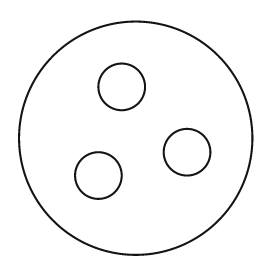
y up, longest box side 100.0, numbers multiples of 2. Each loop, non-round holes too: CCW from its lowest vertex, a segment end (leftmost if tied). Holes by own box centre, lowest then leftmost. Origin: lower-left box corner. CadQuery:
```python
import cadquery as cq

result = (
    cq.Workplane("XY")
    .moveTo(50.0, 50.0)
    .circle(50.0)
    .moveTo(34.0, 34.0)
    .circle(10.0)
    .moveTo(72.0, 44.0)
    .circle(10.0)
    .moveTo(44.0, 72.0)
    .circle(10.0)
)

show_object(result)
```